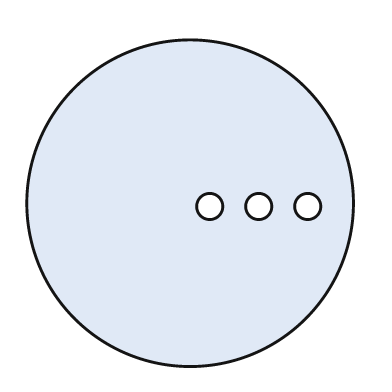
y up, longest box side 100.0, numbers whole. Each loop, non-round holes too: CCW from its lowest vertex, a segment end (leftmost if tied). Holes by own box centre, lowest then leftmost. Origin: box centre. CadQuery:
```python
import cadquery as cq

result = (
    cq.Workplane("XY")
    .moveTo(0.0, 0.0)
    .circle(50.0)
    .moveTo(6.0, -1.0)
    .circle(4.0)
    .moveTo(21.0, -1.0)
    .circle(4.0)
    .moveTo(36.0, -1.0)
    .circle(4.0)
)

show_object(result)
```